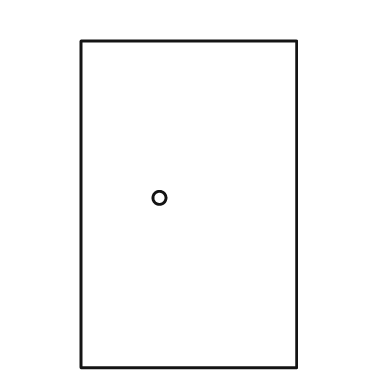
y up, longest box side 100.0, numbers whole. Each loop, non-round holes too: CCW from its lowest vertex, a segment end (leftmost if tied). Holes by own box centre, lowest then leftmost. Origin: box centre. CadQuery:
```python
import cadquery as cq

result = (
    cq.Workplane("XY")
    .moveTo(-33.0, -50.0)
    .lineTo(33.0, -50.0)
    .lineTo(33.0, 50.0)
    .lineTo(-33.0, 50.0)
    .close()
    .moveTo(-9.0, 2.0)
    .circle(2.0)
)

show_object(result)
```